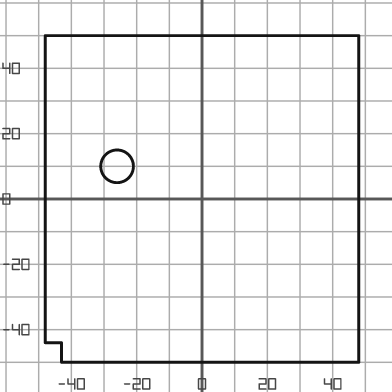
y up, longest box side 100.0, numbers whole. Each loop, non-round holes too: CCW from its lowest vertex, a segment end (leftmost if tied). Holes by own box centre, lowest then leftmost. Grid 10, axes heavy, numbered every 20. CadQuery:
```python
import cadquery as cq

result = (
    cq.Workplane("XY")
    .moveTo(-43.0, -50.0)
    .lineTo(48.0, -50.0)
    .lineTo(48.0, 50.0)
    .lineTo(-48.0, 50.0)
    .lineTo(-48.0, -44.0)
    .lineTo(-43.0, -44.0)
    .close()
    .moveTo(-26.0, 10.0)
    .circle(5.0)
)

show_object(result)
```